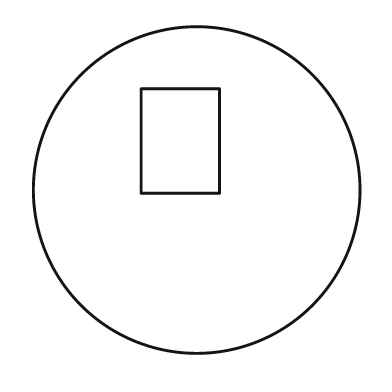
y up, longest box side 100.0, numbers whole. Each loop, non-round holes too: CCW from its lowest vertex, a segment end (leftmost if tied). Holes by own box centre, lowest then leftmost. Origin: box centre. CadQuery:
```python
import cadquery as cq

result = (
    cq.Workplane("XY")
    .moveTo(0.0, 0.0)
    .circle(50.0)
    .moveTo(-17.0, -1.0)
    .lineTo(7.0, -1.0)
    .lineTo(7.0, 31.0)
    .lineTo(-17.0, 31.0)
    .close()
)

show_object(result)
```